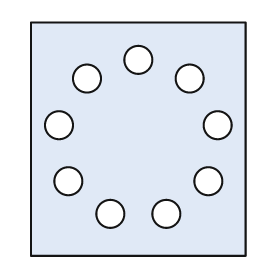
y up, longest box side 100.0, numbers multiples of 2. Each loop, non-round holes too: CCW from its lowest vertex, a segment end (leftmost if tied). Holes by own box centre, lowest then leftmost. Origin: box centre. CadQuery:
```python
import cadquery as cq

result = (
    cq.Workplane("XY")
    .moveTo(-46.0, -50.0)
    .lineTo(46.0, -50.0)
    .lineTo(46.0, 50.0)
    .lineTo(-46.0, 50.0)
    .close()
    .moveTo(-12.0, -32.0)
    .circle(6.0)
    .moveTo(12.0, -32.0)
    .circle(6.0)
    .moveTo(-30.0, -18.0)
    .circle(6.0)
    .moveTo(30.0, -18.0)
    .circle(6.0)
    .moveTo(-34.0, 6.0)
    .circle(6.0)
    .moveTo(34.0, 6.0)
    .circle(6.0)
    .moveTo(-22.0, 26.0)
    .circle(6.0)
    .moveTo(22.0, 26.0)
    .circle(6.0)
    .moveTo(0.0, 34.0)
    .circle(6.0)
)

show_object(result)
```